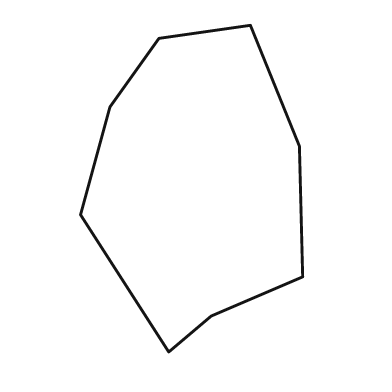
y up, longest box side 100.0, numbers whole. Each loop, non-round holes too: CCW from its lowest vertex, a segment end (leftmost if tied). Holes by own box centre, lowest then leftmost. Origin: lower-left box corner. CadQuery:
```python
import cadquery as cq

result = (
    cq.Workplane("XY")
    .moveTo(27.0, 0.0)
    .lineTo(40.0, 11.0)
    .lineTo(68.0, 23.0)
    .lineTo(67.0, 63.0)
    .lineTo(52.0, 100.0)
    .lineTo(24.0, 96.0)
    .lineTo(9.0, 75.0)
    .lineTo(0.0, 42.0)
    .close()
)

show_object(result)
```